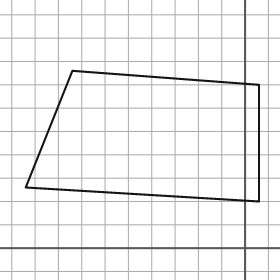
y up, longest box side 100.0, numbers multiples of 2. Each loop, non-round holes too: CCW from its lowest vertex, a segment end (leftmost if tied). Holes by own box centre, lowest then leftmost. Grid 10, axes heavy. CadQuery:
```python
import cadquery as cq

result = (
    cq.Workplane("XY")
    .moveTo(6.0, 20.0)
    .lineTo(6.0, 70.0)
    .lineTo(-74.0, 76.0)
    .lineTo(-94.0, 26.0)
    .close()
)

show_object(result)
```